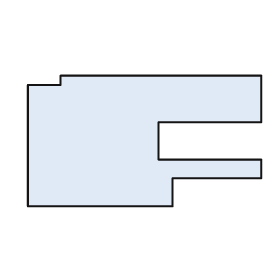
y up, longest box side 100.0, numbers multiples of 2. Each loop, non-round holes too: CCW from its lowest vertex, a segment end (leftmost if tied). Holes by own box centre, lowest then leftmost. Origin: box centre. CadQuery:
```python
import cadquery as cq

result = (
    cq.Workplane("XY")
    .moveTo(-50.0, -28.0)
    .lineTo(12.0, -28.0)
    .lineTo(12.0, -16.0)
    .lineTo(50.0, -16.0)
    .lineTo(50.0, -8.0)
    .lineTo(6.0, -8.0)
    .lineTo(6.0, 8.0)
    .lineTo(50.0, 8.0)
    .lineTo(50.0, 28.0)
    .lineTo(-36.0, 28.0)
    .lineTo(-36.0, 24.0)
    .lineTo(-50.0, 24.0)
    .close()
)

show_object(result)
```